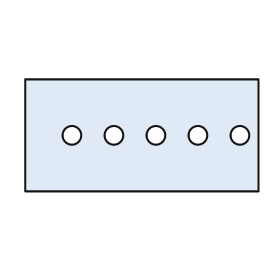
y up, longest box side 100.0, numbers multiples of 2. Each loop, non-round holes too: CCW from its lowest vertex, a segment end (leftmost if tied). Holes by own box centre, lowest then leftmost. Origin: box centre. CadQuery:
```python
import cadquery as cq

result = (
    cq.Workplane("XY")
    .moveTo(-50.0, -24.0)
    .lineTo(50.0, -24.0)
    .lineTo(50.0, 24.0)
    .lineTo(-50.0, 24.0)
    .close()
    .moveTo(-30.0, 0.0)
    .circle(4.0)
    .moveTo(-12.0, 0.0)
    .circle(4.0)
    .moveTo(6.0, 0.0)
    .circle(4.0)
    .moveTo(24.0, 0.0)
    .circle(4.0)
    .moveTo(42.0, 0.0)
    .circle(4.0)
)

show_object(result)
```